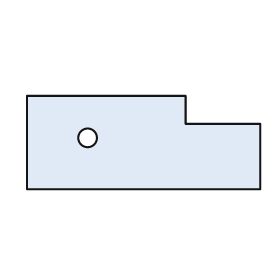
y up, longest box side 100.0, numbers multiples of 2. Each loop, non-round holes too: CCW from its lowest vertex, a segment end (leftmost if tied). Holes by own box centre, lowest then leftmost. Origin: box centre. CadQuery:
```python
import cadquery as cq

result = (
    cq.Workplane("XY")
    .moveTo(-50.0, -20.0)
    .lineTo(50.0, -20.0)
    .lineTo(50.0, 8.0)
    .lineTo(18.0, 8.0)
    .lineTo(18.0, 20.0)
    .lineTo(-50.0, 20.0)
    .close()
    .moveTo(-24.0, 2.0)
    .circle(4.0)
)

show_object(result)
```